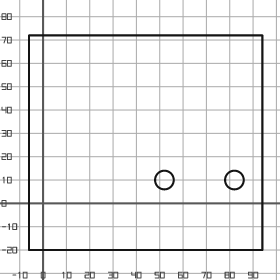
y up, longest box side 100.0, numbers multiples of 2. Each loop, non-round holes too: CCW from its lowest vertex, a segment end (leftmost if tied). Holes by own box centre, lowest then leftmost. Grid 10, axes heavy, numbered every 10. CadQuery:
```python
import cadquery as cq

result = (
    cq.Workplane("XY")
    .moveTo(-6.0, -20.0)
    .lineTo(94.0, -20.0)
    .lineTo(94.0, 72.0)
    .lineTo(-6.0, 72.0)
    .close()
    .moveTo(52.0, 10.0)
    .circle(4.0)
    .moveTo(82.0, 10.0)
    .circle(4.0)
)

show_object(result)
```